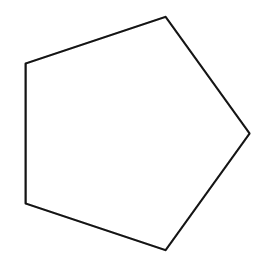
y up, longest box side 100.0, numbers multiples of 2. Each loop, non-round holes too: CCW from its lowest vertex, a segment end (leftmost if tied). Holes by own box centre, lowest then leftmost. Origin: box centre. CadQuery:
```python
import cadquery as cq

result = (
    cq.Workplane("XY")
    .moveTo(12.0, -50.0)
    .lineTo(48.0, 0.0)
    .lineTo(12.0, 50.0)
    .lineTo(-48.0, 30.0)
    .lineTo(-48.0, -30.0)
    .close()
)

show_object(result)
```